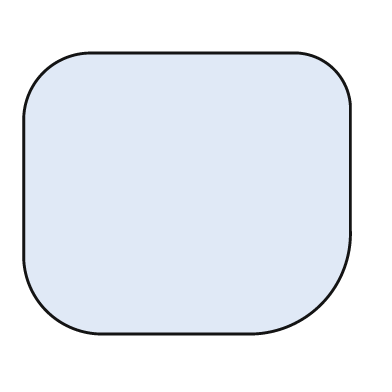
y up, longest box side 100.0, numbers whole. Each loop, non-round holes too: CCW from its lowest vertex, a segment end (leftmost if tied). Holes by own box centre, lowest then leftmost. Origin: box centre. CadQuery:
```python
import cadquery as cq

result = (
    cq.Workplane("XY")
    .moveTo(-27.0, -43.0)
    .lineTo(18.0, -43.0)
    .threePointArc((41.0, -34.0), (50.0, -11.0))
    .lineTo(50.0, 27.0)
    .threePointArc((45.0, 38.0), (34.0, 43.0))
    .lineTo(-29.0, 43.0)
    .threePointArc((-44.0, 37.0), (-50.0, 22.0))
    .lineTo(-50.0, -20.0)
    .threePointArc((-43.0, -36.0), (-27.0, -43.0))
    .close()
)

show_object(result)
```